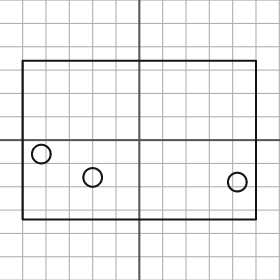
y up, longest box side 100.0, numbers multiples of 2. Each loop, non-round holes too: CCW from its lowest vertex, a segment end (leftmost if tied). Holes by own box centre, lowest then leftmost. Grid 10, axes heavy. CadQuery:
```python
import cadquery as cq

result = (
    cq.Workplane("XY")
    .moveTo(-50.0, -34.0)
    .lineTo(50.0, -34.0)
    .lineTo(50.0, 34.0)
    .lineTo(-50.0, 34.0)
    .close()
    .moveTo(42.0, -18.0)
    .circle(4.0)
    .moveTo(-20.0, -16.0)
    .circle(4.0)
    .moveTo(-42.0, -6.0)
    .circle(4.0)
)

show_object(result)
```